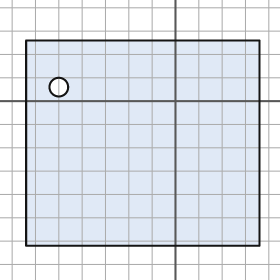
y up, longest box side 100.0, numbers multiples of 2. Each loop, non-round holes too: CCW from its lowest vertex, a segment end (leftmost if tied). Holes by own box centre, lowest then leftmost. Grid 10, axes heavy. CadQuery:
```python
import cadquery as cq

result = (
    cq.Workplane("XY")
    .moveTo(-64.0, -62.0)
    .lineTo(36.0, -62.0)
    .lineTo(36.0, 26.0)
    .lineTo(-64.0, 26.0)
    .close()
    .moveTo(-50.0, 6.0)
    .circle(4.0)
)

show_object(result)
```